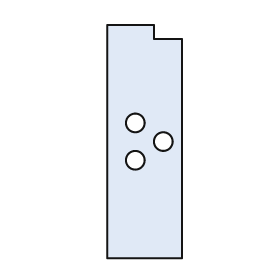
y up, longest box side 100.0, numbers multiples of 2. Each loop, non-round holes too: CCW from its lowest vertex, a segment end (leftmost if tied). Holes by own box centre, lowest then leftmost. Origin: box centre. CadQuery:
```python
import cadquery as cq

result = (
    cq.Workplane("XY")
    .moveTo(-16.0, -50.0)
    .lineTo(16.0, -50.0)
    .lineTo(16.0, 44.0)
    .lineTo(4.0, 44.0)
    .lineTo(4.0, 50.0)
    .lineTo(-16.0, 50.0)
    .close()
    .moveTo(-4.0, -8.0)
    .circle(4.0)
    .moveTo(8.0, 0.0)
    .circle(4.0)
    .moveTo(-4.0, 8.0)
    .circle(4.0)
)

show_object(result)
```